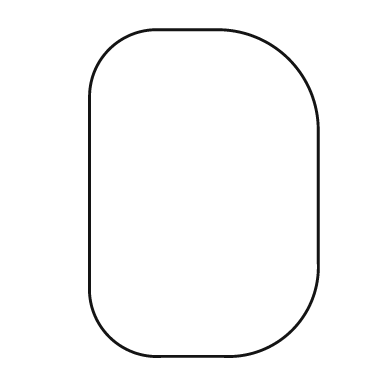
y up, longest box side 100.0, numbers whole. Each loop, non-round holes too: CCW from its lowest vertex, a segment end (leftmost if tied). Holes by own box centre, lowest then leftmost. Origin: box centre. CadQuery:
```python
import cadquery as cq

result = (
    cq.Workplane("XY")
    .moveTo(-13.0, -50.0)
    .lineTo(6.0, -50.0)
    .threePointArc((27.0, -42.0), (35.0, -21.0))
    .lineTo(35.0, 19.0)
    .threePointArc((26.0, 41.0), (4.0, 50.0))
    .lineTo(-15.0, 50.0)
    .threePointArc((-29.0, 44.0), (-35.0, 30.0))
    .lineTo(-35.0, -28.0)
    .threePointArc((-29.0, -44.0), (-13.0, -50.0))
    .close()
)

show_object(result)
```